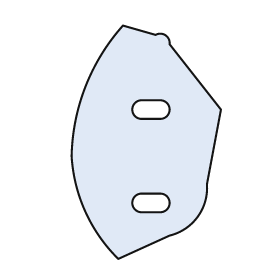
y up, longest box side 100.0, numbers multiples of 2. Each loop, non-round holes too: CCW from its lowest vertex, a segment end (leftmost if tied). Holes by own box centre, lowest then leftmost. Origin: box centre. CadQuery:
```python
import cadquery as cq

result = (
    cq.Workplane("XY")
    .moveTo(-12.0, -50.0)
    .lineTo(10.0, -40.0)
    .threePointArc((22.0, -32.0), (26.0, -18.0))
    .lineTo(32.0, 14.0)
    .lineTo(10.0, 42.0)
    .threePointArc((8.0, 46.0), (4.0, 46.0))
    .lineTo(-10.0, 50.0)
    .threePointArc((-26.0, 24.0), (-32.0, -6.0))
    .threePointArc((-26.0, -30.0), (-12.0, -50.0))
    .close()
    .moveTo(-2.0, -30.0)
    .lineTo(6.0, -30.0)
    .threePointArc((10.0, -26.0), (6.0, -22.0))
    .lineTo(-2.0, -22.0)
    .threePointArc((-6.0, -26.0), (-2.0, -30.0))
    .close()
    .moveTo(-2.0, 10.0)
    .lineTo(6.0, 10.0)
    .threePointArc((10.0, 14.0), (6.0, 18.0))
    .lineTo(-2.0, 18.0)
    .threePointArc((-6.0, 14.0), (-2.0, 10.0))
    .close()
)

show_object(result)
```